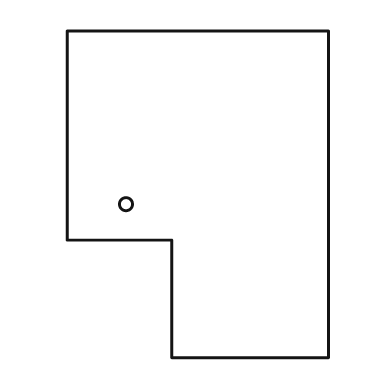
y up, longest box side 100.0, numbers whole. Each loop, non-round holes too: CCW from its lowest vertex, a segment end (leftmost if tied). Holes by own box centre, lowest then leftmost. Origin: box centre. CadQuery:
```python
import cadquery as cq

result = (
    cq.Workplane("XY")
    .moveTo(-8.0, -50.0)
    .lineTo(40.0, -50.0)
    .lineTo(40.0, 50.0)
    .lineTo(-40.0, 50.0)
    .lineTo(-40.0, -14.0)
    .lineTo(-8.0, -14.0)
    .close()
    .moveTo(-22.0, -3.0)
    .circle(2.0)
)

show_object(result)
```